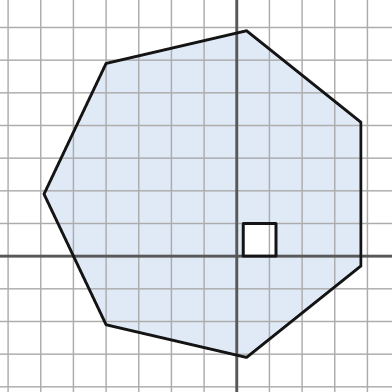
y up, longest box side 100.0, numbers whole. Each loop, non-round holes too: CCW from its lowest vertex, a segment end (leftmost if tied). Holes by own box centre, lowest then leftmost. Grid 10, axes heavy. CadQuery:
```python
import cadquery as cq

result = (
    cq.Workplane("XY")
    .moveTo(3.0, -31.0)
    .lineTo(38.0, -3.0)
    .lineTo(38.0, 41.0)
    .lineTo(3.0, 69.0)
    .lineTo(-40.0, 59.0)
    .lineTo(-59.0, 19.0)
    .lineTo(-40.0, -21.0)
    .close()
    .moveTo(2.0, 0.0)
    .lineTo(12.0, 0.0)
    .lineTo(12.0, 10.0)
    .lineTo(2.0, 10.0)
    .close()
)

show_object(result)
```